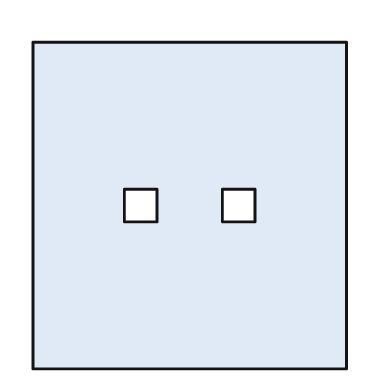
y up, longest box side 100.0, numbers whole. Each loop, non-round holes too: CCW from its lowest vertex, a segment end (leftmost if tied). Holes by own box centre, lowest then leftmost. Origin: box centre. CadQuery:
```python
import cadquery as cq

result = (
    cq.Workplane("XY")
    .moveTo(-48.0, -50.0)
    .lineTo(48.0, -50.0)
    .lineTo(48.0, 50.0)
    .lineTo(-48.0, 50.0)
    .close()
    .moveTo(-20.0, -5.0)
    .lineTo(-10.0, -5.0)
    .lineTo(-10.0, 5.0)
    .lineTo(-20.0, 5.0)
    .close()
    .moveTo(10.0, -5.0)
    .lineTo(20.0, -5.0)
    .lineTo(20.0, 5.0)
    .lineTo(10.0, 5.0)
    .close()
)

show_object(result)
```